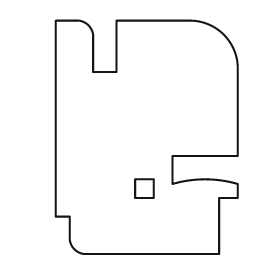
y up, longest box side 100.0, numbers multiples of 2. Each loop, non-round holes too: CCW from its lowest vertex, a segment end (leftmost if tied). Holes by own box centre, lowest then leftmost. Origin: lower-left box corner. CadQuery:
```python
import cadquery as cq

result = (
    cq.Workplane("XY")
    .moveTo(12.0, 0.0)
    .lineTo(70.0, 0.0)
    .lineTo(70.0, 24.0)
    .lineTo(78.0, 24.0)
    .lineTo(78.0, 30.0)
    .threePointArc((64.0, 32.0), (50.0, 30.0))
    .lineTo(50.0, 42.0)
    .lineTo(78.0, 42.0)
    .lineTo(78.0, 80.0)
    .threePointArc((72.0, 94.0), (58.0, 100.0))
    .lineTo(26.0, 100.0)
    .lineTo(26.0, 78.0)
    .lineTo(16.0, 78.0)
    .lineTo(16.0, 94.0)
    .threePointArc((14.0, 98.0), (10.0, 100.0))
    .lineTo(0.0, 100.0)
    .lineTo(0.0, 16.0)
    .lineTo(6.0, 16.0)
    .lineTo(6.0, 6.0)
    .threePointArc((8.0, 2.0), (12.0, 0.0))
    .close()
    .moveTo(34.0, 24.0)
    .lineTo(42.0, 24.0)
    .lineTo(42.0, 32.0)
    .lineTo(34.0, 32.0)
    .close()
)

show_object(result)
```